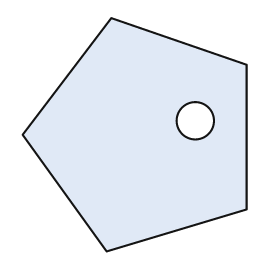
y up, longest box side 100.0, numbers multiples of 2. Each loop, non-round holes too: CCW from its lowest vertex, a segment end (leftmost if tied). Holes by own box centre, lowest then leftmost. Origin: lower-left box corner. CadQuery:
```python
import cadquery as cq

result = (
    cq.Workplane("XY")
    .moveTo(36.0, 0.0)
    .lineTo(96.0, 18.0)
    .lineTo(96.0, 80.0)
    .lineTo(38.0, 100.0)
    .lineTo(0.0, 50.0)
    .close()
    .moveTo(74.0, 56.0)
    .circle(8.0)
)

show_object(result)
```